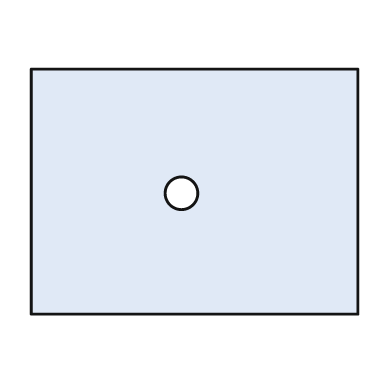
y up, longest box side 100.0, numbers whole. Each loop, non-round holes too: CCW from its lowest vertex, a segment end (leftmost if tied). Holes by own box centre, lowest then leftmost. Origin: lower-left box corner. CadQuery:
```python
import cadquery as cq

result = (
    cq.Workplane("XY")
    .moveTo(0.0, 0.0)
    .lineTo(100.0, 0.0)
    .lineTo(100.0, 75.0)
    .lineTo(0.0, 75.0)
    .close()
    .moveTo(46.0, 37.0)
    .circle(5.0)
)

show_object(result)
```